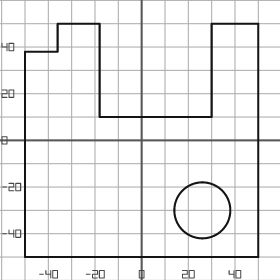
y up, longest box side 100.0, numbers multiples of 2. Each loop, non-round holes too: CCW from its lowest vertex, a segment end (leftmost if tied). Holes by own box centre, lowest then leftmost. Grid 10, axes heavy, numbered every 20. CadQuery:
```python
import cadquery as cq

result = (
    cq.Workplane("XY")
    .moveTo(-50.0, -50.0)
    .lineTo(50.0, -50.0)
    .lineTo(50.0, 50.0)
    .lineTo(30.0, 50.0)
    .lineTo(30.0, 10.0)
    .lineTo(-18.0, 10.0)
    .lineTo(-18.0, 50.0)
    .lineTo(-36.0, 50.0)
    .lineTo(-36.0, 38.0)
    .lineTo(-50.0, 38.0)
    .close()
    .moveTo(26.0, -30.0)
    .circle(12.0)
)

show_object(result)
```